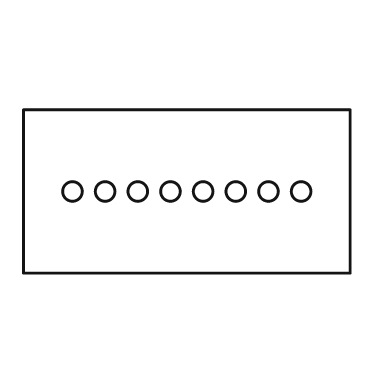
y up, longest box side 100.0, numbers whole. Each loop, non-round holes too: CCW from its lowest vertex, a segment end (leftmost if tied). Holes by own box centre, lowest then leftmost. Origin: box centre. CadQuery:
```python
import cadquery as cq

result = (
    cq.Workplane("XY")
    .moveTo(-50.0, -25.0)
    .lineTo(50.0, -25.0)
    .lineTo(50.0, 25.0)
    .lineTo(-50.0, 25.0)
    .close()
    .moveTo(-35.0, 0.0)
    .circle(3.0)
    .moveTo(-25.0, 0.0)
    .circle(3.0)
    .moveTo(-15.0, 0.0)
    .circle(3.0)
    .moveTo(-5.0, 0.0)
    .circle(3.0)
    .moveTo(5.0, 0.0)
    .circle(3.0)
    .moveTo(15.0, 0.0)
    .circle(3.0)
    .moveTo(25.0, 0.0)
    .circle(3.0)
    .moveTo(35.0, 0.0)
    .circle(3.0)
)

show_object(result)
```